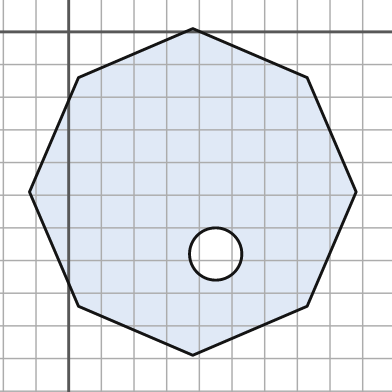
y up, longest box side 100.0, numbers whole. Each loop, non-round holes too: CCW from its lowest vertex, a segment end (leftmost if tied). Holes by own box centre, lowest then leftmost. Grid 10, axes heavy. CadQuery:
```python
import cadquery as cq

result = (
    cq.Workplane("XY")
    .moveTo(38.0, -99.0)
    .lineTo(73.0, -84.0)
    .lineTo(88.0, -49.0)
    .lineTo(73.0, -14.0)
    .lineTo(38.0, 1.0)
    .lineTo(3.0, -14.0)
    .lineTo(-12.0, -49.0)
    .lineTo(3.0, -84.0)
    .close()
    .moveTo(45.0, -68.0)
    .circle(8.0)
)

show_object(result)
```